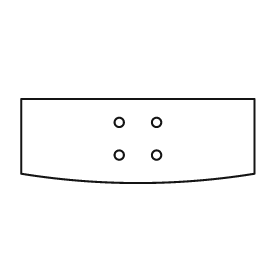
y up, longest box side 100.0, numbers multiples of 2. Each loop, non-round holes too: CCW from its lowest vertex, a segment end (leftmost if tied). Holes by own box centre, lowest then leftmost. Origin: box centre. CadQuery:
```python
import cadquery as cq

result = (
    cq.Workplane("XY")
    .moveTo(-50.0, -14.0)
    .threePointArc((0.0, -18.0), (50.0, -14.0))
    .lineTo(50.0, 18.0)
    .lineTo(-50.0, 18.0)
    .close()
    .moveTo(-8.0, -6.0)
    .circle(2.0)
    .moveTo(8.0, -6.0)
    .circle(2.0)
    .moveTo(-8.0, 8.0)
    .circle(2.0)
    .moveTo(8.0, 8.0)
    .circle(2.0)
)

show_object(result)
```